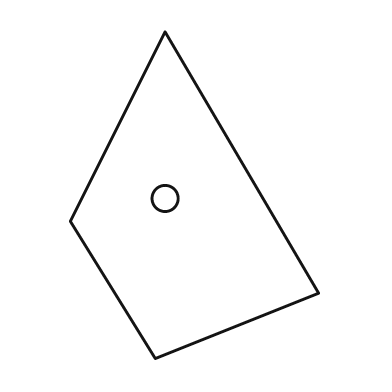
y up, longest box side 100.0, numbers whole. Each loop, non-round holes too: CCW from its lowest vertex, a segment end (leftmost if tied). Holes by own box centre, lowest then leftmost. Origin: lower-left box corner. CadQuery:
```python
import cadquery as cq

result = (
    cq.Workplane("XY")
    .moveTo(26.0, 0.0)
    .lineTo(76.0, 20.0)
    .lineTo(29.0, 100.0)
    .lineTo(0.0, 42.0)
    .close()
    .moveTo(29.0, 49.0)
    .circle(4.0)
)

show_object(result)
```